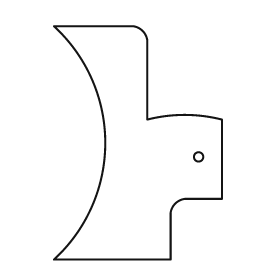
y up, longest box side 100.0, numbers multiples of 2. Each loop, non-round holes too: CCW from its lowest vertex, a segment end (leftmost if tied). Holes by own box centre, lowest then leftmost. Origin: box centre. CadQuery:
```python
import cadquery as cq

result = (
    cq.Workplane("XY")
    .moveTo(-36.0, -50.0)
    .lineTo(14.0, -50.0)
    .lineTo(14.0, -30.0)
    .threePointArc((16.0, -26.0), (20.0, -24.0))
    .lineTo(36.0, -24.0)
    .lineTo(36.0, 10.0)
    .threePointArc((20.0, 12.0), (4.0, 10.0))
    .lineTo(4.0, 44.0)
    .threePointArc((2.0, 48.0), (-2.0, 50.0))
    .lineTo(-36.0, 50.0)
    .threePointArc((-14.0, 0.0), (-36.0, -50.0))
    .close()
    .moveTo(26.0, -6.0)
    .circle(2.0)
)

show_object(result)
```